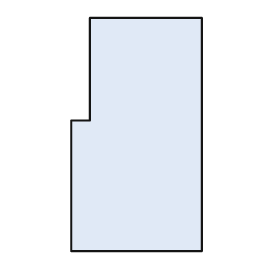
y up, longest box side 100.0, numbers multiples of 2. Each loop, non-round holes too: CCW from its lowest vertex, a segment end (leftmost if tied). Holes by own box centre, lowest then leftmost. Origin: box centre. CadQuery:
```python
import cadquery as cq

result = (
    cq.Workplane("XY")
    .moveTo(-28.0, -50.0)
    .lineTo(28.0, -50.0)
    .lineTo(28.0, 50.0)
    .lineTo(-20.0, 50.0)
    .lineTo(-20.0, 6.0)
    .lineTo(-28.0, 6.0)
    .close()
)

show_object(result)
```